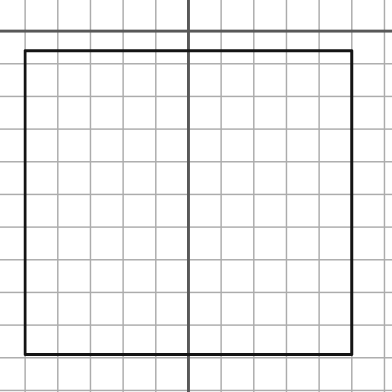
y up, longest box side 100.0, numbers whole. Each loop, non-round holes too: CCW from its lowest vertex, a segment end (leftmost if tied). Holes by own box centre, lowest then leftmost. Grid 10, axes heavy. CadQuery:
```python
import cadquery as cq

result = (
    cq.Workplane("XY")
    .moveTo(-50.0, -99.0)
    .lineTo(50.0, -99.0)
    .lineTo(50.0, -6.0)
    .lineTo(-50.0, -6.0)
    .close()
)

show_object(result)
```